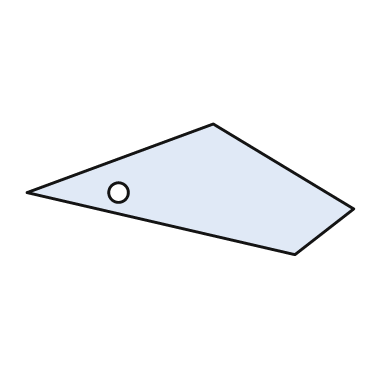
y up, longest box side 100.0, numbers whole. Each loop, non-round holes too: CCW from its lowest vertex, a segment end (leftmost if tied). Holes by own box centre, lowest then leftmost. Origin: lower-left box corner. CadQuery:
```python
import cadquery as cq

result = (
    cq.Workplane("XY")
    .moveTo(82.0, 0.0)
    .lineTo(100.0, 14.0)
    .lineTo(57.0, 40.0)
    .lineTo(0.0, 19.0)
    .close()
    .moveTo(28.0, 19.0)
    .circle(3.0)
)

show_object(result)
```